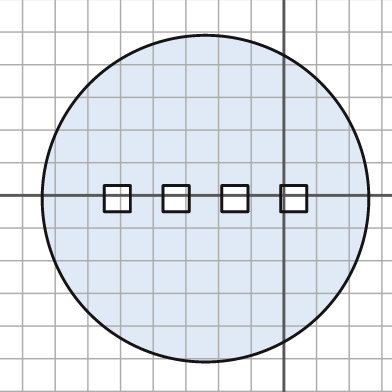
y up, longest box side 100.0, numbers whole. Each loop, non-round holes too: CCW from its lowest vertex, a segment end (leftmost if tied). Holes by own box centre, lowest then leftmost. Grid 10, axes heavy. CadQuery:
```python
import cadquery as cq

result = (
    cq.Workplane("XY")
    .moveTo(-24.0, -1.0)
    .circle(50.0)
    .moveTo(-55.0, -5.0)
    .lineTo(-47.0, -5.0)
    .lineTo(-47.0, 3.0)
    .lineTo(-55.0, 3.0)
    .close()
    .moveTo(-37.0, -5.0)
    .lineTo(-29.0, -5.0)
    .lineTo(-29.0, 3.0)
    .lineTo(-37.0, 3.0)
    .close()
    .moveTo(-19.0, -5.0)
    .lineTo(-11.0, -5.0)
    .lineTo(-11.0, 3.0)
    .lineTo(-19.0, 3.0)
    .close()
    .moveTo(-1.0, -5.0)
    .lineTo(7.0, -5.0)
    .lineTo(7.0, 3.0)
    .lineTo(-1.0, 3.0)
    .close()
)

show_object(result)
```